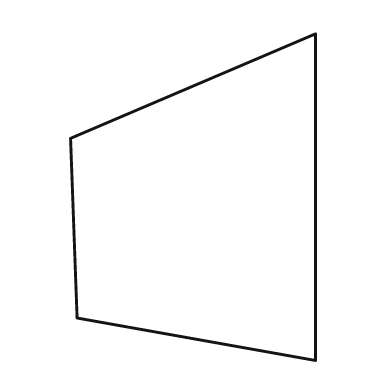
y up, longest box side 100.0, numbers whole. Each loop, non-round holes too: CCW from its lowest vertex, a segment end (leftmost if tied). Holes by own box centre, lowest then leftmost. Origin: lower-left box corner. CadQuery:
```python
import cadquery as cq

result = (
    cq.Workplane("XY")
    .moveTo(75.0, 0.0)
    .lineTo(75.0, 100.0)
    .lineTo(0.0, 68.0)
    .lineTo(2.0, 13.0)
    .close()
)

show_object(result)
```